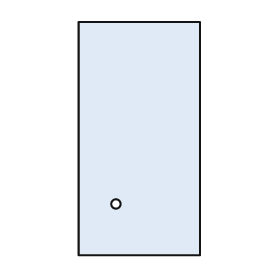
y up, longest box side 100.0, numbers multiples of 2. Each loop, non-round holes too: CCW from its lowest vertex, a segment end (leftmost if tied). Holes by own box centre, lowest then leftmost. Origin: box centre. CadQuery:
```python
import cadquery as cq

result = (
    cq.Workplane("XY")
    .moveTo(-26.0, -50.0)
    .lineTo(26.0, -50.0)
    .lineTo(26.0, 50.0)
    .lineTo(-26.0, 50.0)
    .close()
    .moveTo(-10.0, -28.0)
    .circle(2.0)
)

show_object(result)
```